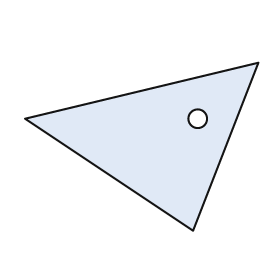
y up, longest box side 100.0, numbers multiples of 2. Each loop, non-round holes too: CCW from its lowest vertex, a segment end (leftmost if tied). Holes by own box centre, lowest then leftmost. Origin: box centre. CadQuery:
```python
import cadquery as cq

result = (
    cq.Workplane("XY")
    .moveTo(22.0, -36.0)
    .lineTo(50.0, 36.0)
    .lineTo(-50.0, 12.0)
    .close()
    .moveTo(24.0, 12.0)
    .circle(4.0)
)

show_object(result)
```